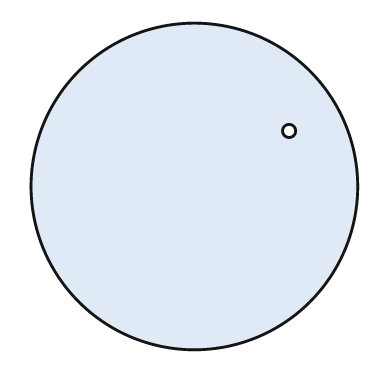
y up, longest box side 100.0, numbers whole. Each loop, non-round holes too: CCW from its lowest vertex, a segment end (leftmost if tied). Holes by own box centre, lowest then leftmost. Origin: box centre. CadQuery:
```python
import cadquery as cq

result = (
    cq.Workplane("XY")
    .moveTo(0.0, 0.0)
    .circle(50.0)
    .moveTo(29.0, 17.0)
    .circle(2.0)
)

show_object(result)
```